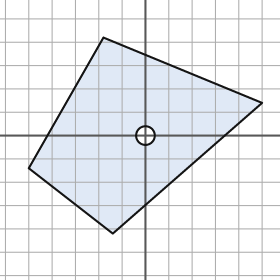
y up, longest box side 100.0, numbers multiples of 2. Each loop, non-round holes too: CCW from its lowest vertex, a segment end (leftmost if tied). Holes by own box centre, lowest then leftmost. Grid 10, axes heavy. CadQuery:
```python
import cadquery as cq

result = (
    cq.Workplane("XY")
    .moveTo(-14.0, -42.0)
    .lineTo(50.0, 14.0)
    .lineTo(-18.0, 42.0)
    .lineTo(-50.0, -14.0)
    .close()
    .moveTo(0.0, 0.0)
    .circle(4.0)
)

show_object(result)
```